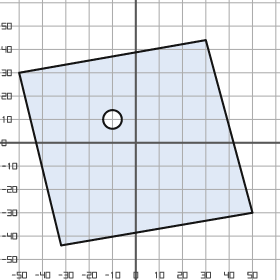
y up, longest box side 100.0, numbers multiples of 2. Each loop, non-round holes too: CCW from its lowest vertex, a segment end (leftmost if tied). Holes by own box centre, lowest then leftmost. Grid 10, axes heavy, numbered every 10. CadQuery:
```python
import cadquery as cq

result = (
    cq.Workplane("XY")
    .moveTo(-32.0, -44.0)
    .lineTo(50.0, -30.0)
    .lineTo(30.0, 44.0)
    .lineTo(-50.0, 30.0)
    .close()
    .moveTo(-10.0, 10.0)
    .circle(4.0)
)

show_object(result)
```